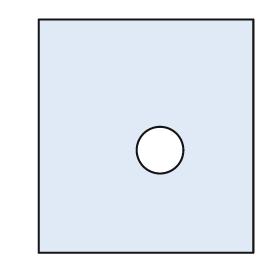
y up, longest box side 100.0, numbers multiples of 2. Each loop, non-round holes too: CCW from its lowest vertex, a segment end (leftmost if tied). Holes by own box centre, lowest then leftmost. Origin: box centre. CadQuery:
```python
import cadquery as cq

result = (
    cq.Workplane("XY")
    .moveTo(-46.0, -50.0)
    .lineTo(46.0, -50.0)
    .lineTo(46.0, 50.0)
    .lineTo(-46.0, 50.0)
    .close()
    .moveTo(6.0, -6.0)
    .circle(10.0)
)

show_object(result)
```